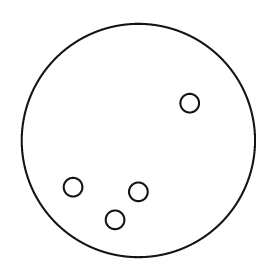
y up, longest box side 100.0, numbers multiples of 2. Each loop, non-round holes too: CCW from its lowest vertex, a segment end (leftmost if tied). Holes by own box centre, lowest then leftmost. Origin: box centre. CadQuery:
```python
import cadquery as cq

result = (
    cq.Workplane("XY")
    .moveTo(0.0, 0.0)
    .circle(50.0)
    .moveTo(-10.0, -34.0)
    .circle(4.0)
    .moveTo(0.0, -22.0)
    .circle(4.0)
    .moveTo(-28.0, -20.0)
    .circle(4.0)
    .moveTo(22.0, 16.0)
    .circle(4.0)
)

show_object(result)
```